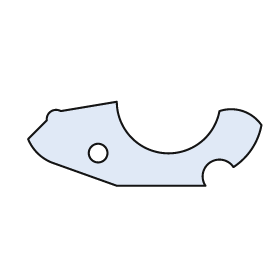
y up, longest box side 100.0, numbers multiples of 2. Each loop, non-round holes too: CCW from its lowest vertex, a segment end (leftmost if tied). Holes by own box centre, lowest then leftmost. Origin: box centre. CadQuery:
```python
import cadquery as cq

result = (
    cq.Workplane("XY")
    .moveTo(-12.0, -18.0)
    .lineTo(26.0, -18.0)
    .threePointArc((28.0, -8.0), (38.0, -10.0))
    .threePointArc((46.0, -2.0), (50.0, 8.0))
    .threePointArc((42.0, 14.0), (32.0, 14.0))
    .threePointArc((8.0, -4.0), (-12.0, 18.0))
    .lineTo(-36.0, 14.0)
    .threePointArc((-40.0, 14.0), (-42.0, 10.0))
    .lineTo(-50.0, 2.0)
    .threePointArc((-46.0, -4.0), (-40.0, -8.0))
    .close()
    .moveTo(-20.0, -4.0)
    .circle(4.0)
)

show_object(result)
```